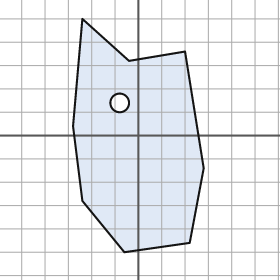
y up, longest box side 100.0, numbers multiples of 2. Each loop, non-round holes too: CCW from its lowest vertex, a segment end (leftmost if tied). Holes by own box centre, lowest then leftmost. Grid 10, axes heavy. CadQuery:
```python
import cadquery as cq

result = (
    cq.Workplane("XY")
    .moveTo(-6.0, -50.0)
    .lineTo(22.0, -46.0)
    .lineTo(28.0, -14.0)
    .lineTo(20.0, 36.0)
    .lineTo(-4.0, 32.0)
    .lineTo(-24.0, 50.0)
    .lineTo(-28.0, 4.0)
    .lineTo(-24.0, -28.0)
    .close()
    .moveTo(-8.0, 14.0)
    .circle(4.0)
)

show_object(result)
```